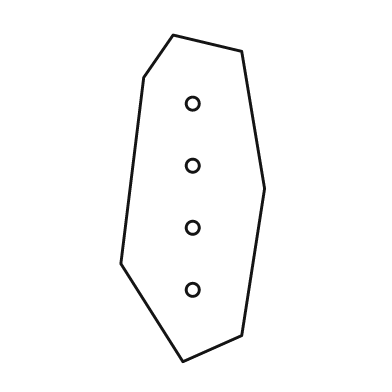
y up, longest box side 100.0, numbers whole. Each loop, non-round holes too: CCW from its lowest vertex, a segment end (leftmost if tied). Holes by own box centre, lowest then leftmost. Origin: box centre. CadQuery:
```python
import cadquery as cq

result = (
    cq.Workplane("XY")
    .moveTo(-3.0, -50.0)
    .lineTo(15.0, -42.0)
    .lineTo(22.0, 3.0)
    .lineTo(15.0, 45.0)
    .lineTo(-6.0, 50.0)
    .lineTo(-15.0, 37.0)
    .lineTo(-22.0, -20.0)
    .close()
    .moveTo(0.0, -28.0)
    .circle(2.0)
    .moveTo(0.0, -9.0)
    .circle(2.0)
    .moveTo(0.0, 10.0)
    .circle(2.0)
    .moveTo(0.0, 29.0)
    .circle(2.0)
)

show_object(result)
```